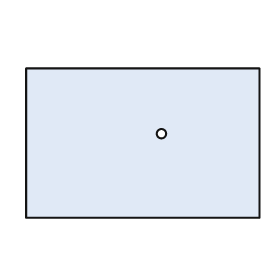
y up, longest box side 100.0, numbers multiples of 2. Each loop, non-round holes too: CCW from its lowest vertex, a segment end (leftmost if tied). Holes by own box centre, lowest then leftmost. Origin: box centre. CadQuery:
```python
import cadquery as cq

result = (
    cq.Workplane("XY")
    .moveTo(-50.0, -32.0)
    .lineTo(50.0, -32.0)
    .lineTo(50.0, 32.0)
    .lineTo(-50.0, 32.0)
    .close()
    .moveTo(8.0, 4.0)
    .circle(2.0)
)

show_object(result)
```